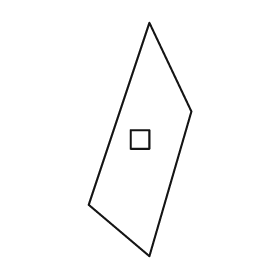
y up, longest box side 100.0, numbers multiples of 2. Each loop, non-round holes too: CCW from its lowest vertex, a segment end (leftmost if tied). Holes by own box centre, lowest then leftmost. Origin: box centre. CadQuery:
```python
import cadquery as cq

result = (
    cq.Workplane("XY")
    .moveTo(4.0, -50.0)
    .lineTo(22.0, 12.0)
    .lineTo(4.0, 50.0)
    .lineTo(-22.0, -28.0)
    .close()
    .moveTo(-4.0, -4.0)
    .lineTo(4.0, -4.0)
    .lineTo(4.0, 4.0)
    .lineTo(-4.0, 4.0)
    .close()
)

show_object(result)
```